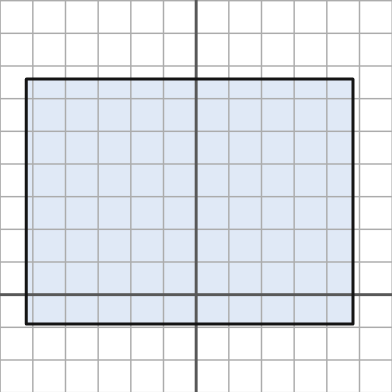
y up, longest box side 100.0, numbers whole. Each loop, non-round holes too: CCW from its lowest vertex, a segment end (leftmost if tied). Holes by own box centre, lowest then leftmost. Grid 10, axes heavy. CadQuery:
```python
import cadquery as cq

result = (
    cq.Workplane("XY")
    .moveTo(-52.0, -9.0)
    .lineTo(48.0, -9.0)
    .lineTo(48.0, 66.0)
    .lineTo(-52.0, 66.0)
    .close()
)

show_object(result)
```